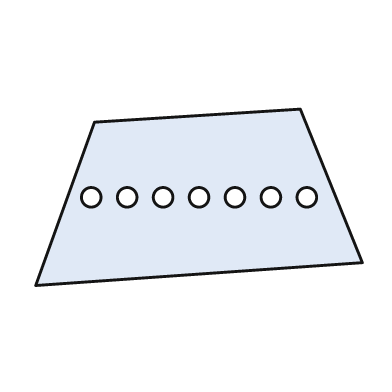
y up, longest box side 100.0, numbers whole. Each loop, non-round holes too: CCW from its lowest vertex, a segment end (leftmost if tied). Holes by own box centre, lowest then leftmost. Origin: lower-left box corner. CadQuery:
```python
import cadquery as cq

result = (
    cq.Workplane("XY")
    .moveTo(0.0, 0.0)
    .lineTo(100.0, 7.0)
    .lineTo(81.0, 54.0)
    .lineTo(18.0, 50.0)
    .close()
    .moveTo(17.0, 27.0)
    .circle(3.0)
    .moveTo(28.0, 27.0)
    .circle(3.0)
    .moveTo(39.0, 27.0)
    .circle(3.0)
    .moveTo(50.0, 27.0)
    .circle(3.0)
    .moveTo(61.0, 27.0)
    .circle(3.0)
    .moveTo(72.0, 27.0)
    .circle(3.0)
    .moveTo(83.0, 27.0)
    .circle(3.0)
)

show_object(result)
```